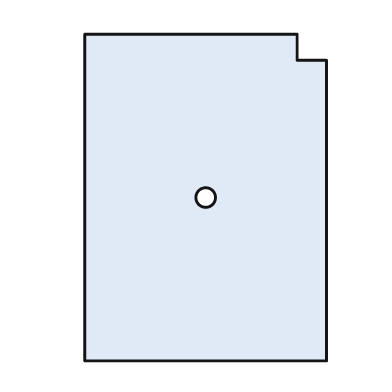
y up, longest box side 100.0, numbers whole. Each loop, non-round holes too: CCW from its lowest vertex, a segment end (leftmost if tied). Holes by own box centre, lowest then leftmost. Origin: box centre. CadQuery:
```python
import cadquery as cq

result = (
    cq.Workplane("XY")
    .moveTo(-37.0, -50.0)
    .lineTo(37.0, -50.0)
    .lineTo(37.0, 42.0)
    .lineTo(28.0, 42.0)
    .lineTo(28.0, 50.0)
    .lineTo(-37.0, 50.0)
    .close()
    .moveTo(0.0, 0.0)
    .circle(3.0)
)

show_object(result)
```